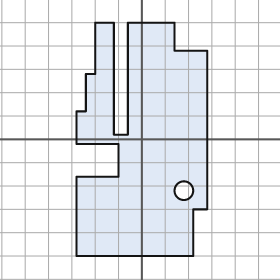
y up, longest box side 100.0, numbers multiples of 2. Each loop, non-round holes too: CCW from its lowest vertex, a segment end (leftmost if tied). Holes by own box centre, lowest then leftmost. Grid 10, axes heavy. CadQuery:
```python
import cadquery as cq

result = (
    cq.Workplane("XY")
    .moveTo(-28.0, -50.0)
    .lineTo(22.0, -50.0)
    .lineTo(22.0, -30.0)
    .lineTo(28.0, -30.0)
    .lineTo(28.0, 38.0)
    .lineTo(14.0, 38.0)
    .lineTo(14.0, 50.0)
    .lineTo(-6.0, 50.0)
    .lineTo(-6.0, 2.0)
    .lineTo(-12.0, 2.0)
    .lineTo(-12.0, 50.0)
    .lineTo(-20.0, 50.0)
    .lineTo(-20.0, 28.0)
    .lineTo(-24.0, 28.0)
    .lineTo(-24.0, 12.0)
    .lineTo(-28.0, 12.0)
    .lineTo(-28.0, -2.0)
    .lineTo(-10.0, -2.0)
    .lineTo(-10.0, -16.0)
    .lineTo(-28.0, -16.0)
    .close()
    .moveTo(18.0, -22.0)
    .circle(4.0)
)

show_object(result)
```